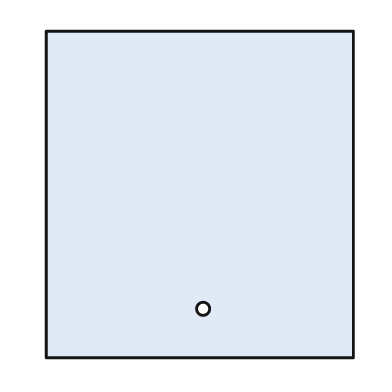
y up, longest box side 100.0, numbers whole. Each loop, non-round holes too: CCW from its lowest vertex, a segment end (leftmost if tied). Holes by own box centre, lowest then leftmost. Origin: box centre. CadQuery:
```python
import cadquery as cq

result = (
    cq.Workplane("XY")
    .moveTo(-47.0, -50.0)
    .lineTo(47.0, -50.0)
    .lineTo(47.0, 50.0)
    .lineTo(-47.0, 50.0)
    .close()
    .moveTo(1.0, -35.0)
    .circle(2.0)
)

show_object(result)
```